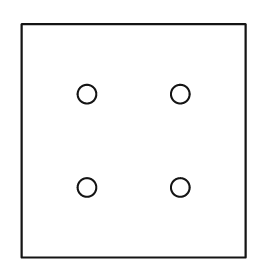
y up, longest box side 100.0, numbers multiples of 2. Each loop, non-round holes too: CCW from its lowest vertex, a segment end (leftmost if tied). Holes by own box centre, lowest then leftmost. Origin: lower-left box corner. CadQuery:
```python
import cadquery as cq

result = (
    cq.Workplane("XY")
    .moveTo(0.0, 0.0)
    .lineTo(96.0, 0.0)
    .lineTo(96.0, 100.0)
    .lineTo(0.0, 100.0)
    .close()
    .moveTo(28.0, 30.0)
    .circle(4.0)
    .moveTo(68.0, 30.0)
    .circle(4.0)
    .moveTo(28.0, 70.0)
    .circle(4.0)
    .moveTo(68.0, 70.0)
    .circle(4.0)
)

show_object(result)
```